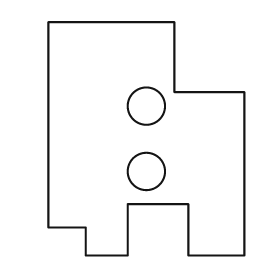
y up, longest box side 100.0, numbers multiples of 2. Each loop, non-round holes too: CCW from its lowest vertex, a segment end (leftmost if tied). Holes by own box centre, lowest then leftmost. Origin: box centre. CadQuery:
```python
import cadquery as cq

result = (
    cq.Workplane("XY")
    .moveTo(-26.0, -50.0)
    .lineTo(-8.0, -50.0)
    .lineTo(-8.0, -28.0)
    .lineTo(18.0, -28.0)
    .lineTo(18.0, -50.0)
    .lineTo(42.0, -50.0)
    .lineTo(42.0, 20.0)
    .lineTo(12.0, 20.0)
    .lineTo(12.0, 50.0)
    .lineTo(-42.0, 50.0)
    .lineTo(-42.0, -38.0)
    .lineTo(-26.0, -38.0)
    .close()
    .moveTo(0.0, -14.0)
    .circle(8.0)
    .moveTo(0.0, 14.0)
    .circle(8.0)
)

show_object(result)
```